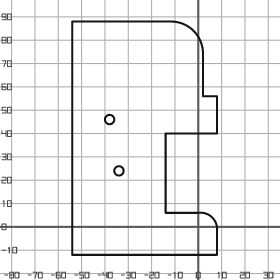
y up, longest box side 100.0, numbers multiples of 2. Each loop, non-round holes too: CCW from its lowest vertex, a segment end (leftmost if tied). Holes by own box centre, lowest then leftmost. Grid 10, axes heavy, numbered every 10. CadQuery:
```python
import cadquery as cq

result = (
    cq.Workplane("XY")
    .moveTo(-54.0, -12.0)
    .lineTo(8.0, -12.0)
    .lineTo(8.0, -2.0)
    .threePointArc((6.0, 4.0), (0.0, 6.0))
    .lineTo(-14.0, 6.0)
    .lineTo(-14.0, 40.0)
    .lineTo(8.0, 40.0)
    .lineTo(8.0, 56.0)
    .lineTo(2.0, 56.0)
    .lineTo(2.0, 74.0)
    .threePointArc((-2.0, 84.0), (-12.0, 88.0))
    .lineTo(-54.0, 88.0)
    .close()
    .moveTo(-34.0, 24.0)
    .circle(2.0)
    .moveTo(-38.0, 46.0)
    .circle(2.0)
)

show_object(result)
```